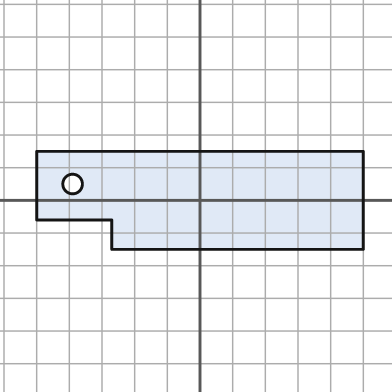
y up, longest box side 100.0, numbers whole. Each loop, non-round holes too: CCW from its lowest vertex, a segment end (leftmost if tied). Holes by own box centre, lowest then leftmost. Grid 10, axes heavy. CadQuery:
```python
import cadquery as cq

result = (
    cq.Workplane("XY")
    .moveTo(-27.0, -15.0)
    .lineTo(50.0, -15.0)
    .lineTo(50.0, 15.0)
    .lineTo(-50.0, 15.0)
    .lineTo(-50.0, -6.0)
    .lineTo(-27.0, -6.0)
    .close()
    .moveTo(-39.0, 5.0)
    .circle(3.0)
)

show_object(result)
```